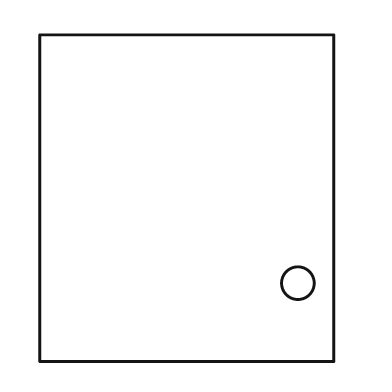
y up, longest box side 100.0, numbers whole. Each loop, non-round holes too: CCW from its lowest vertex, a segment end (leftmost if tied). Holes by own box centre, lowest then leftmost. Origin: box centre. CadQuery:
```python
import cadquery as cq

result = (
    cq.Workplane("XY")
    .moveTo(-45.0, -50.0)
    .lineTo(45.0, -50.0)
    .lineTo(45.0, 50.0)
    .lineTo(-45.0, 50.0)
    .close()
    .moveTo(34.0, -26.0)
    .circle(5.0)
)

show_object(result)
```